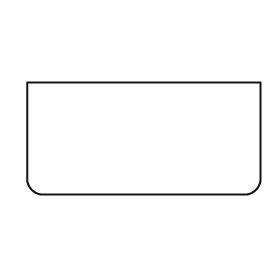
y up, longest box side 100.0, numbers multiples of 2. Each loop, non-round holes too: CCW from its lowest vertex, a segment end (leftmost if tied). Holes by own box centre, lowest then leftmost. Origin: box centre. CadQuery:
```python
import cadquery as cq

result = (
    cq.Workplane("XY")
    .moveTo(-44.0, -24.0)
    .lineTo(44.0, -24.0)
    .threePointArc((48.0, -22.0), (50.0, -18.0))
    .lineTo(50.0, 24.0)
    .lineTo(-50.0, 24.0)
    .lineTo(-50.0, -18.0)
    .threePointArc((-48.0, -22.0), (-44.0, -24.0))
    .close()
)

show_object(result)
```